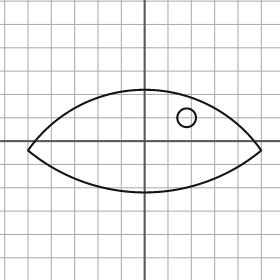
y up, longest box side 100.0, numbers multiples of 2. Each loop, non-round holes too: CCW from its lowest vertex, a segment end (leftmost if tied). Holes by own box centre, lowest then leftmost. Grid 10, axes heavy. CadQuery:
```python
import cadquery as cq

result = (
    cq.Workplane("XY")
    .moveTo(-50.0, -4.0)
    .threePointArc((0.0, -22.0), (50.0, -4.0))
    .threePointArc((0.0, 22.0), (-50.0, -4.0))
    .close()
    .moveTo(18.0, 10.0)
    .circle(4.0)
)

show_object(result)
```